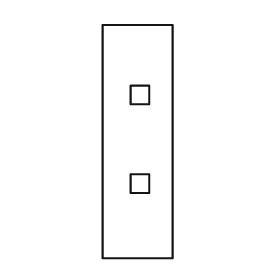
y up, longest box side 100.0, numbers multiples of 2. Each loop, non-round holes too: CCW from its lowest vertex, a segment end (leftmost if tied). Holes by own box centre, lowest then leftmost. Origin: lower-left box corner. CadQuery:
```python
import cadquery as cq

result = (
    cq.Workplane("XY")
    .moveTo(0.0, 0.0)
    .lineTo(30.0, 0.0)
    .lineTo(30.0, 100.0)
    .lineTo(0.0, 100.0)
    .close()
    .moveTo(12.0, 28.0)
    .lineTo(20.0, 28.0)
    .lineTo(20.0, 36.0)
    .lineTo(12.0, 36.0)
    .close()
    .moveTo(12.0, 66.0)
    .lineTo(20.0, 66.0)
    .lineTo(20.0, 74.0)
    .lineTo(12.0, 74.0)
    .close()
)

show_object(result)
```